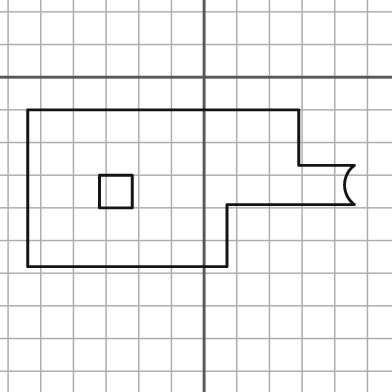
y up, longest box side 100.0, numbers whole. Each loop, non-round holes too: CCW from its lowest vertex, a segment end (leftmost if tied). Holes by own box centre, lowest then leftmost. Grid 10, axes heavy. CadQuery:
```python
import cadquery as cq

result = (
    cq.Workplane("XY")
    .moveTo(-54.0, -58.0)
    .lineTo(7.0, -58.0)
    .lineTo(7.0, -39.0)
    .lineTo(46.0, -39.0)
    .threePointArc((43.0, -33.0), (46.0, -27.0))
    .lineTo(29.0, -27.0)
    .lineTo(29.0, -10.0)
    .lineTo(-54.0, -10.0)
    .close()
    .moveTo(-32.0, -40.0)
    .lineTo(-22.0, -40.0)
    .lineTo(-22.0, -30.0)
    .lineTo(-32.0, -30.0)
    .close()
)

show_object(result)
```